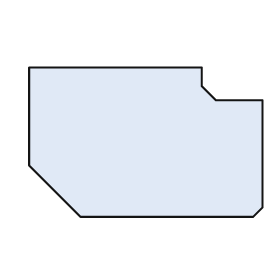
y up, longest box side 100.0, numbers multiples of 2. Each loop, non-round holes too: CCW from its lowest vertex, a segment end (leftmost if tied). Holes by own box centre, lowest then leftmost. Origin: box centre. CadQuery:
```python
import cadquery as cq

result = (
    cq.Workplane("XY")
    .moveTo(-28.0, -32.0)
    .lineTo(46.0, -32.0)
    .lineTo(50.0, -28.0)
    .lineTo(50.0, 18.0)
    .lineTo(30.0, 18.0)
    .lineTo(24.0, 24.0)
    .lineTo(24.0, 32.0)
    .lineTo(-50.0, 32.0)
    .lineTo(-50.0, -10.0)
    .close()
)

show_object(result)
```